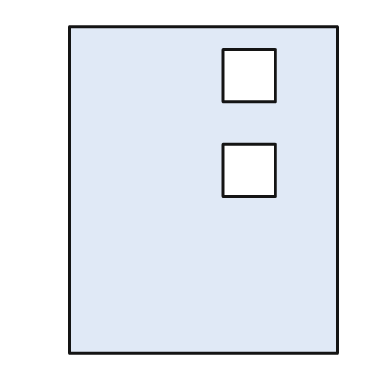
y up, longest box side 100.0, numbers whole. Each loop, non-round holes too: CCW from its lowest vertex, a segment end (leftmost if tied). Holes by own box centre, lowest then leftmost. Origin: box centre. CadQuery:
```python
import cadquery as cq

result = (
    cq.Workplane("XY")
    .moveTo(-41.0, -50.0)
    .lineTo(41.0, -50.0)
    .lineTo(41.0, 50.0)
    .lineTo(-41.0, 50.0)
    .close()
    .moveTo(6.0, -2.0)
    .lineTo(22.0, -2.0)
    .lineTo(22.0, 14.0)
    .lineTo(6.0, 14.0)
    .close()
    .moveTo(6.0, 27.0)
    .lineTo(22.0, 27.0)
    .lineTo(22.0, 43.0)
    .lineTo(6.0, 43.0)
    .close()
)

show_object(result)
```